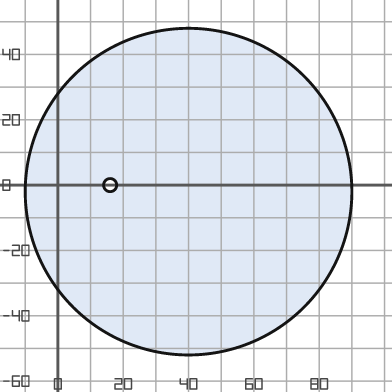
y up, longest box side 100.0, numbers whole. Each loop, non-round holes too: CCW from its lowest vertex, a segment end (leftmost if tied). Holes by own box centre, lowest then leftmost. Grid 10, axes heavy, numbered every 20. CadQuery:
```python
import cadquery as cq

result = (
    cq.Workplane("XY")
    .moveTo(40.0, -2.0)
    .circle(50.0)
    .moveTo(16.0, 0.0)
    .circle(2.0)
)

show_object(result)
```